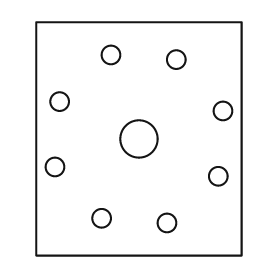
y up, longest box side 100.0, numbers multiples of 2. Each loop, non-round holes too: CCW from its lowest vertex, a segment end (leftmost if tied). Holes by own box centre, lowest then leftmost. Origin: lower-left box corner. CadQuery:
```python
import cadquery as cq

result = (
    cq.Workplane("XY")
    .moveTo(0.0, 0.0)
    .lineTo(88.0, 0.0)
    .lineTo(88.0, 100.0)
    .lineTo(0.0, 100.0)
    .close()
    .moveTo(56.0, 14.0)
    .circle(4.0)
    .moveTo(28.0, 16.0)
    .circle(4.0)
    .moveTo(78.0, 34.0)
    .circle(4.0)
    .moveTo(8.0, 38.0)
    .circle(4.0)
    .moveTo(44.0, 50.0)
    .circle(8.0)
    .moveTo(80.0, 62.0)
    .circle(4.0)
    .moveTo(10.0, 66.0)
    .circle(4.0)
    .moveTo(60.0, 84.0)
    .circle(4.0)
    .moveTo(32.0, 86.0)
    .circle(4.0)
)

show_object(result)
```